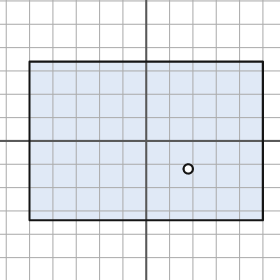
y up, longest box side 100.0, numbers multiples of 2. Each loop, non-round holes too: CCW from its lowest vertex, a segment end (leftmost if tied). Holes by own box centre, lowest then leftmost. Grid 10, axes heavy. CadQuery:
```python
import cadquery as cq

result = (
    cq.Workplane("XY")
    .moveTo(-50.0, -34.0)
    .lineTo(50.0, -34.0)
    .lineTo(50.0, 34.0)
    .lineTo(-50.0, 34.0)
    .close()
    .moveTo(18.0, -12.0)
    .circle(2.0)
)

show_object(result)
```